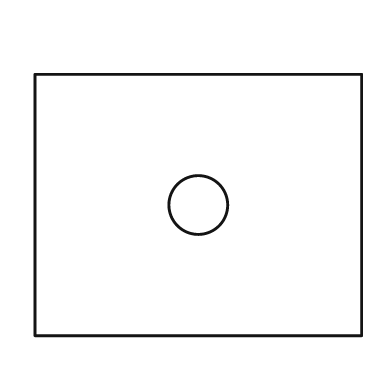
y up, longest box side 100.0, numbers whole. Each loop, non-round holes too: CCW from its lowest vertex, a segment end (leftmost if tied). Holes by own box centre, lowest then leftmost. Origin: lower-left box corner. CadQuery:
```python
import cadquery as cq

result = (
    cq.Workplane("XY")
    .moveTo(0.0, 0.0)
    .lineTo(100.0, 0.0)
    .lineTo(100.0, 80.0)
    .lineTo(0.0, 80.0)
    .close()
    .moveTo(50.0, 40.0)
    .circle(9.0)
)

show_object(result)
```